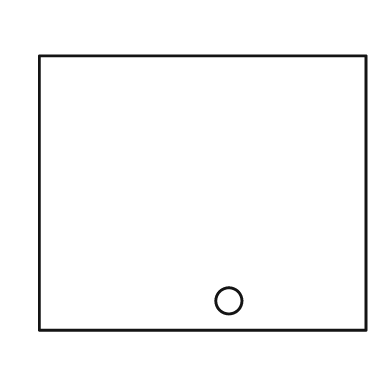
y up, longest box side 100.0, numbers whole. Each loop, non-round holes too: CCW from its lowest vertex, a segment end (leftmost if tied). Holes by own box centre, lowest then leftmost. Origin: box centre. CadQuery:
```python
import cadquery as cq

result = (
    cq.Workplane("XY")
    .moveTo(-50.0, -42.0)
    .lineTo(50.0, -42.0)
    .lineTo(50.0, 42.0)
    .lineTo(-50.0, 42.0)
    .close()
    .moveTo(8.0, -33.0)
    .circle(4.0)
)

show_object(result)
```